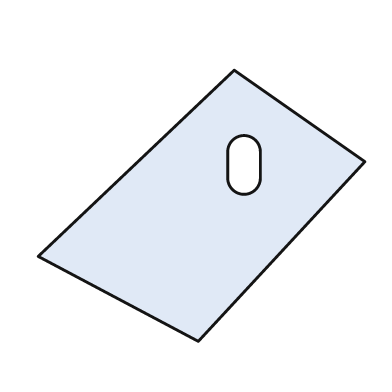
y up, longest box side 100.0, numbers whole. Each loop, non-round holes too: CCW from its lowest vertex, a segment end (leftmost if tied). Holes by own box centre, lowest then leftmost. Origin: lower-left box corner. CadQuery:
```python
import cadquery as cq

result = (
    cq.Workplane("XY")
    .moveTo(49.0, 0.0)
    .lineTo(100.0, 55.0)
    .lineTo(60.0, 83.0)
    .lineTo(0.0, 26.0)
    .close()
    .moveTo(58.0, 50.0)
    .threePointArc((63.0, 45.0), (68.0, 50.0))
    .lineTo(68.0, 58.0)
    .threePointArc((63.0, 63.0), (58.0, 58.0))
    .close()
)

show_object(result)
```